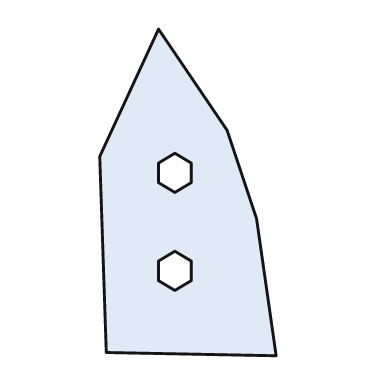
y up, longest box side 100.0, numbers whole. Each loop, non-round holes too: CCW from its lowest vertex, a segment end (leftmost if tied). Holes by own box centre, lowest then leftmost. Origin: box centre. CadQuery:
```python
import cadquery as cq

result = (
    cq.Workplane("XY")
    .moveTo(27.0, -50.0)
    .lineTo(21.0, -8.0)
    .lineTo(12.0, 19.0)
    .lineTo(-9.0, 50.0)
    .lineTo(-27.0, 11.0)
    .lineTo(-25.0, -49.0)
    .close()
    .moveTo(-4.0, -30.0)
    .lineTo(1.0, -27.0)
    .lineTo(1.0, -21.0)
    .lineTo(-4.0, -18.0)
    .lineTo(-9.0, -21.0)
    .lineTo(-9.0, -27.0)
    .close()
    .moveTo(-4.0, 0.0)
    .lineTo(1.0, 3.0)
    .lineTo(1.0, 9.0)
    .lineTo(-4.0, 12.0)
    .lineTo(-9.0, 9.0)
    .lineTo(-9.0, 3.0)
    .close()
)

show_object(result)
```